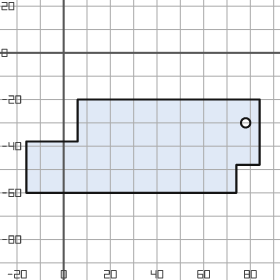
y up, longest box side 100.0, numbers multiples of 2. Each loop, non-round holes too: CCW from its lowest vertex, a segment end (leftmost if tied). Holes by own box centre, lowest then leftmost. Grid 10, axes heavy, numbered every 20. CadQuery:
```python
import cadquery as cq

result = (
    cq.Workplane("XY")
    .moveTo(-16.0, -60.0)
    .lineTo(74.0, -60.0)
    .lineTo(74.0, -48.0)
    .lineTo(84.0, -48.0)
    .lineTo(84.0, -20.0)
    .lineTo(6.0, -20.0)
    .lineTo(6.0, -38.0)
    .lineTo(-16.0, -38.0)
    .close()
    .moveTo(78.0, -30.0)
    .circle(2.0)
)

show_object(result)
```